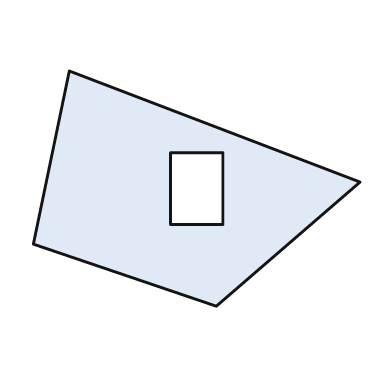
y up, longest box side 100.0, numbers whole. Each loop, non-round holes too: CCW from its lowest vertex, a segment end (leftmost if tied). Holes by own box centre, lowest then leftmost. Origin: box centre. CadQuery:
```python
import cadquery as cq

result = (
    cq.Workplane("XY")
    .moveTo(6.0, -36.0)
    .lineTo(50.0, 2.0)
    .lineTo(-39.0, 36.0)
    .lineTo(-50.0, -17.0)
    .close()
    .moveTo(-8.0, -11.0)
    .lineTo(8.0, -11.0)
    .lineTo(8.0, 11.0)
    .lineTo(-8.0, 11.0)
    .close()
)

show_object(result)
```